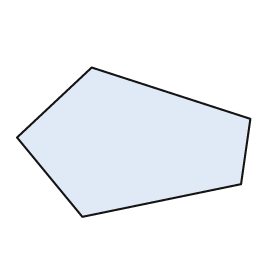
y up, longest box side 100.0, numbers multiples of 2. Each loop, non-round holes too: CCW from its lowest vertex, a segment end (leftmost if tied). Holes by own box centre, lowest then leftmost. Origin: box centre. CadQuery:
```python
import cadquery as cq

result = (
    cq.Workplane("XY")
    .moveTo(-22.0, -32.0)
    .lineTo(46.0, -18.0)
    .lineTo(50.0, 10.0)
    .lineTo(-18.0, 32.0)
    .lineTo(-50.0, 2.0)
    .close()
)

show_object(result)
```